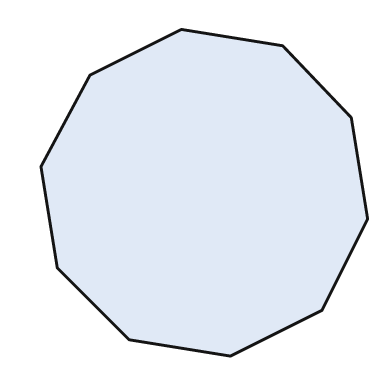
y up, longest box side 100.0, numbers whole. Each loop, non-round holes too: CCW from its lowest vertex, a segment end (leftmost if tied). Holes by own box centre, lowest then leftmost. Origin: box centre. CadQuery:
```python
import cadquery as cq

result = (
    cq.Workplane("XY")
    .moveTo(8.0, -50.0)
    .lineTo(36.0, -36.0)
    .lineTo(50.0, -8.0)
    .lineTo(45.0, 23.0)
    .lineTo(24.0, 45.0)
    .lineTo(-7.0, 50.0)
    .lineTo(-35.0, 36.0)
    .lineTo(-50.0, 8.0)
    .lineTo(-45.0, -23.0)
    .lineTo(-23.0, -45.0)
    .close()
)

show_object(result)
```